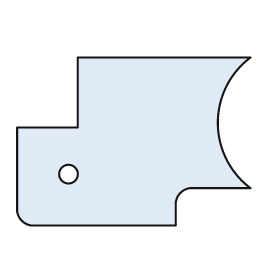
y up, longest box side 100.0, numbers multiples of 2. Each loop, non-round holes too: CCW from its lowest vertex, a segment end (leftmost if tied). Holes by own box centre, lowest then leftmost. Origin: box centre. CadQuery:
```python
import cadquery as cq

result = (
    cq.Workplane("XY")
    .moveTo(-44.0, -36.0)
    .lineTo(18.0, -36.0)
    .lineTo(18.0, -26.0)
    .threePointArc((20.0, -22.0), (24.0, -20.0))
    .lineTo(50.0, -20.0)
    .threePointArc((36.0, 8.0), (50.0, 36.0))
    .lineTo(-24.0, 36.0)
    .lineTo(-24.0, 6.0)
    .lineTo(-50.0, 6.0)
    .lineTo(-50.0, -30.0)
    .threePointArc((-48.0, -34.0), (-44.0, -36.0))
    .close()
    .moveTo(-28.0, -14.0)
    .circle(4.0)
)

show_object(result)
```